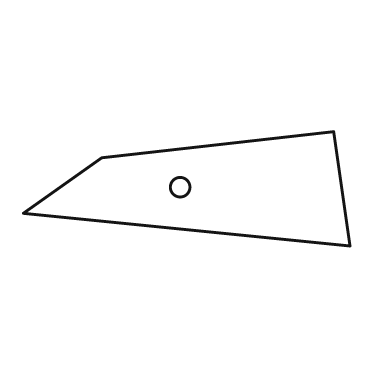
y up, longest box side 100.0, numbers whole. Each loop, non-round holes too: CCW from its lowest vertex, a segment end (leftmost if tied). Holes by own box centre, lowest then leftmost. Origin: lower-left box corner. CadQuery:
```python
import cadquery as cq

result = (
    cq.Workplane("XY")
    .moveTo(100.0, 0.0)
    .lineTo(95.0, 35.0)
    .lineTo(24.0, 27.0)
    .lineTo(0.0, 10.0)
    .close()
    .moveTo(48.0, 18.0)
    .circle(3.0)
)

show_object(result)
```